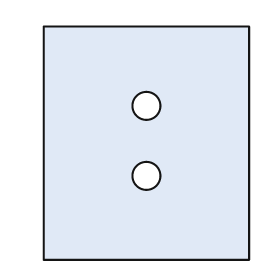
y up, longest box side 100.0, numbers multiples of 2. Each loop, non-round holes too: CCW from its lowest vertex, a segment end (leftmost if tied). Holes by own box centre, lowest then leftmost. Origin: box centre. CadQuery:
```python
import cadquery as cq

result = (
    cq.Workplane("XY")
    .moveTo(-44.0, -50.0)
    .lineTo(44.0, -50.0)
    .lineTo(44.0, 50.0)
    .lineTo(-44.0, 50.0)
    .close()
    .moveTo(0.0, -14.0)
    .circle(6.0)
    .moveTo(0.0, 16.0)
    .circle(6.0)
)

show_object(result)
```